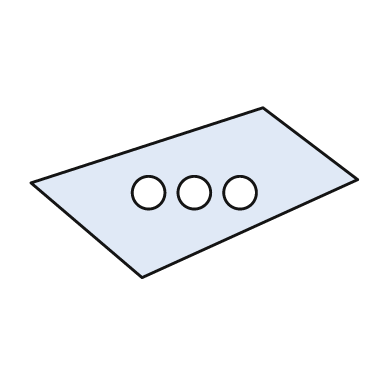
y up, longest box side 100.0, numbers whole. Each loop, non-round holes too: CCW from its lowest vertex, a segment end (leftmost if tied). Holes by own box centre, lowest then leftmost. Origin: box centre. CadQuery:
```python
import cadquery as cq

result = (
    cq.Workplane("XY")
    .moveTo(-16.0, -26.0)
    .lineTo(50.0, 4.0)
    .lineTo(21.0, 26.0)
    .lineTo(-50.0, 3.0)
    .close()
    .moveTo(-14.0, 0.0)
    .circle(5.0)
    .moveTo(0.0, 0.0)
    .circle(5.0)
    .moveTo(14.0, 0.0)
    .circle(5.0)
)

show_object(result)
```